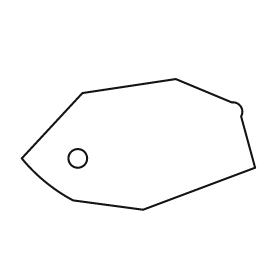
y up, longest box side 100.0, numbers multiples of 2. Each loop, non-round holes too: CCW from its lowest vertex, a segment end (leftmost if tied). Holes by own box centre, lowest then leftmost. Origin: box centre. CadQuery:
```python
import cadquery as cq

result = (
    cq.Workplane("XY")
    .moveTo(2.0, -28.0)
    .lineTo(50.0, -10.0)
    .lineTo(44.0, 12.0)
    .threePointArc((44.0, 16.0), (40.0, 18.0))
    .lineTo(16.0, 28.0)
    .lineTo(-24.0, 22.0)
    .lineTo(-50.0, -6.0)
    .threePointArc((-40.0, -16.0), (-28.0, -24.0))
    .close()
    .moveTo(-26.0, -6.0)
    .circle(4.0)
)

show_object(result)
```